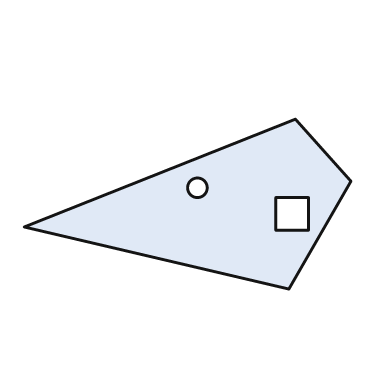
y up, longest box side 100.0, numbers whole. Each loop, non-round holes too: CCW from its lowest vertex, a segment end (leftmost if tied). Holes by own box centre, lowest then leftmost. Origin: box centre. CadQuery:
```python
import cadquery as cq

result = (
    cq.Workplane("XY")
    .moveTo(31.0, -26.0)
    .lineTo(50.0, 7.0)
    .lineTo(33.0, 26.0)
    .lineTo(-50.0, -7.0)
    .close()
    .moveTo(27.0, -8.0)
    .lineTo(37.0, -8.0)
    .lineTo(37.0, 2.0)
    .lineTo(27.0, 2.0)
    .close()
    .moveTo(3.0, 5.0)
    .circle(3.0)
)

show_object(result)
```